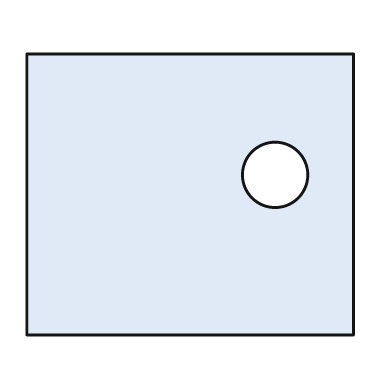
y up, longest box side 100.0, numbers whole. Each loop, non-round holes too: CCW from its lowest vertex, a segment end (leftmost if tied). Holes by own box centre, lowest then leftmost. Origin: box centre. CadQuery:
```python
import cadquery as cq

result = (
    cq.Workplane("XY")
    .moveTo(-50.0, -43.0)
    .lineTo(50.0, -43.0)
    .lineTo(50.0, 43.0)
    .lineTo(-50.0, 43.0)
    .close()
    .moveTo(26.0, 6.0)
    .circle(10.0)
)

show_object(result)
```